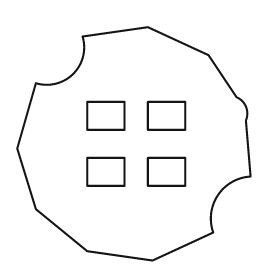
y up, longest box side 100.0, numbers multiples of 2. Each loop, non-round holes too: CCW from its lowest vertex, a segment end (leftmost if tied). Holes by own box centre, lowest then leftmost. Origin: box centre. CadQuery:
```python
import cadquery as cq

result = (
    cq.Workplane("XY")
    .moveTo(8.0, -50.0)
    .lineTo(34.0, -38.0)
    .threePointArc((36.0, -22.0), (50.0, -14.0))
    .lineTo(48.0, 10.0)
    .threePointArc((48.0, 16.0), (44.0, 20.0))
    .lineTo(32.0, 38.0)
    .lineTo(6.0, 50.0)
    .lineTo(-22.0, 46.0)
    .threePointArc((-26.0, 30.0), (-42.0, 26.0))
    .lineTo(-50.0, -2.0)
    .lineTo(-42.0, -28.0)
    .lineTo(-20.0, -46.0)
    .close()
    .moveTo(-20.0, -18.0)
    .lineTo(-4.0, -18.0)
    .lineTo(-4.0, -6.0)
    .lineTo(-20.0, -6.0)
    .close()
    .moveTo(6.0, -18.0)
    .lineTo(22.0, -18.0)
    .lineTo(22.0, -6.0)
    .lineTo(6.0, -6.0)
    .close()
    .moveTo(-20.0, 6.0)
    .lineTo(-4.0, 6.0)
    .lineTo(-4.0, 18.0)
    .lineTo(-20.0, 18.0)
    .close()
    .moveTo(6.0, 6.0)
    .lineTo(22.0, 6.0)
    .lineTo(22.0, 18.0)
    .lineTo(6.0, 18.0)
    .close()
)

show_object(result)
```